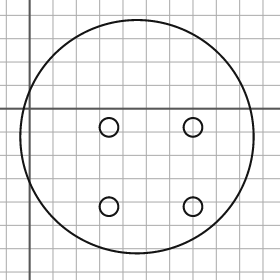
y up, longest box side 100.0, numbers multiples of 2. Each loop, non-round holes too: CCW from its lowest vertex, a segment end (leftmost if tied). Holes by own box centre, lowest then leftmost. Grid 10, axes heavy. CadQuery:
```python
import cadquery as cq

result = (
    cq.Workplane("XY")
    .moveTo(46.0, -12.0)
    .circle(50.0)
    .moveTo(34.0, -42.0)
    .circle(4.0)
    .moveTo(70.0, -42.0)
    .circle(4.0)
    .moveTo(34.0, -8.0)
    .circle(4.0)
    .moveTo(70.0, -8.0)
    .circle(4.0)
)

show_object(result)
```